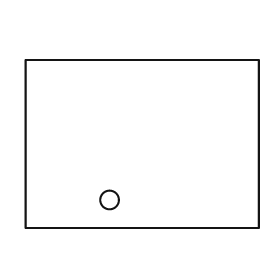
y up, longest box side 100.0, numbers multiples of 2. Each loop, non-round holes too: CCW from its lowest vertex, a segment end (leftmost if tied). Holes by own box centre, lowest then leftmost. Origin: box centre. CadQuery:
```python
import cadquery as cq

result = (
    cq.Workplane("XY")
    .moveTo(-50.0, -36.0)
    .lineTo(50.0, -36.0)
    .lineTo(50.0, 36.0)
    .lineTo(-50.0, 36.0)
    .close()
    .moveTo(-14.0, -24.0)
    .circle(4.0)
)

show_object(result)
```